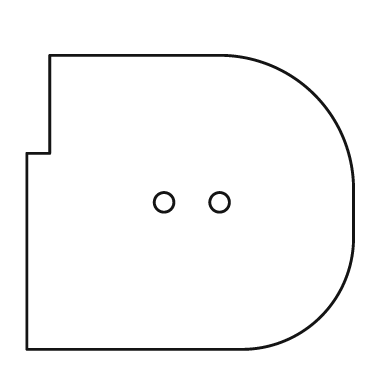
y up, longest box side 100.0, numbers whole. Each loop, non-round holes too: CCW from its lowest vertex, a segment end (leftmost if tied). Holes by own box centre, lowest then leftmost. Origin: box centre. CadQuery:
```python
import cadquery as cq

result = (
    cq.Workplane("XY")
    .moveTo(-50.0, -45.0)
    .lineTo(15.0, -45.0)
    .threePointArc((40.0, -35.0), (50.0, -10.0))
    .lineTo(50.0, 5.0)
    .threePointArc((38.0, 33.0), (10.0, 45.0))
    .lineTo(-43.0, 45.0)
    .lineTo(-43.0, 15.0)
    .lineTo(-50.0, 15.0)
    .close()
    .moveTo(-8.0, 0.0)
    .circle(3.0)
    .moveTo(9.0, 0.0)
    .circle(3.0)
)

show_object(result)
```